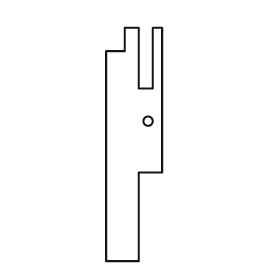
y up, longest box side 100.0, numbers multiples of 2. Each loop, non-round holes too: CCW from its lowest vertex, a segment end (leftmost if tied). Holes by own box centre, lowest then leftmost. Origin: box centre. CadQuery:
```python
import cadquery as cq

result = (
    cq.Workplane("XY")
    .moveTo(-12.0, -50.0)
    .lineTo(2.0, -50.0)
    .lineTo(2.0, -12.0)
    .lineTo(12.0, -12.0)
    .lineTo(12.0, 50.0)
    .lineTo(8.0, 50.0)
    .lineTo(8.0, 24.0)
    .lineTo(2.0, 24.0)
    .lineTo(2.0, 50.0)
    .lineTo(-4.0, 50.0)
    .lineTo(-4.0, 40.0)
    .lineTo(-12.0, 40.0)
    .close()
    .moveTo(6.0, 10.0)
    .circle(2.0)
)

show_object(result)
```